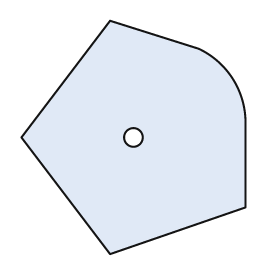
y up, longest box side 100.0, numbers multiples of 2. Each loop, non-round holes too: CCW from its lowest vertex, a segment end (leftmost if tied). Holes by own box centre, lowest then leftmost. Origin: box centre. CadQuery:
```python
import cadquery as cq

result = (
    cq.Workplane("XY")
    .moveTo(-10.0, -50.0)
    .lineTo(48.0, -30.0)
    .lineTo(48.0, 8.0)
    .threePointArc((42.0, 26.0), (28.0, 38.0))
    .lineTo(-10.0, 50.0)
    .lineTo(-48.0, 0.0)
    .close()
    .moveTo(0.0, 0.0)
    .circle(4.0)
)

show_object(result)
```